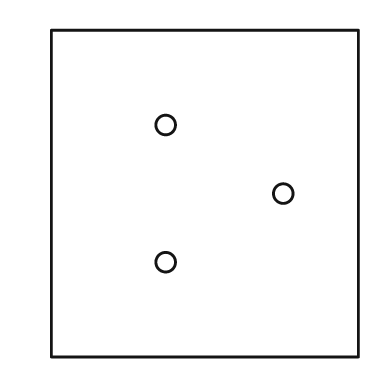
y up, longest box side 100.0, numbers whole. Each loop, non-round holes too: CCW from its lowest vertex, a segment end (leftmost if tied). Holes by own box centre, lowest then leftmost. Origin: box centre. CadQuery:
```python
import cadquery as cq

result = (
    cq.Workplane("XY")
    .moveTo(-47.0, -50.0)
    .lineTo(47.0, -50.0)
    .lineTo(47.0, 50.0)
    .lineTo(-47.0, 50.0)
    .close()
    .moveTo(-12.0, -21.0)
    .circle(3.0)
    .moveTo(24.0, 0.0)
    .circle(3.0)
    .moveTo(-12.0, 21.0)
    .circle(3.0)
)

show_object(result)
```